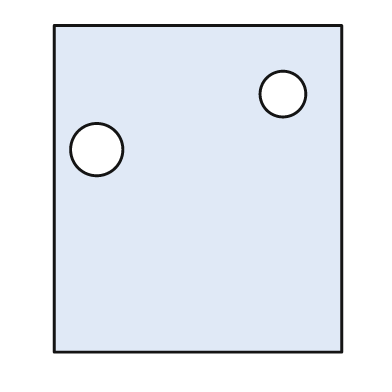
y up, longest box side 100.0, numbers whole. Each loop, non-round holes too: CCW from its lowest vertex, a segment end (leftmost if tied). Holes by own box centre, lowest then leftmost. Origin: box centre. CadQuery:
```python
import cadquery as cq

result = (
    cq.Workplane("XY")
    .moveTo(-44.0, -50.0)
    .lineTo(44.0, -50.0)
    .lineTo(44.0, 50.0)
    .lineTo(-44.0, 50.0)
    .close()
    .moveTo(-31.0, 12.0)
    .circle(8.0)
    .moveTo(26.0, 29.0)
    .circle(7.0)
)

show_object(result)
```